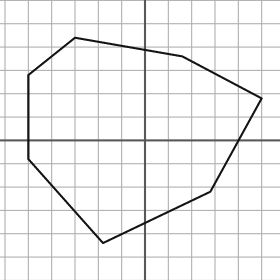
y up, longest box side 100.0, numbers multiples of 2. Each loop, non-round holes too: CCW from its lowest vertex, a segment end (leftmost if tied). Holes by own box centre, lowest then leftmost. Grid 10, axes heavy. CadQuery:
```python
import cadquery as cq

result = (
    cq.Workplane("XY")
    .moveTo(-18.0, -44.0)
    .lineTo(28.0, -22.0)
    .lineTo(50.0, 18.0)
    .lineTo(16.0, 36.0)
    .lineTo(-30.0, 44.0)
    .lineTo(-50.0, 28.0)
    .lineTo(-50.0, -8.0)
    .close()
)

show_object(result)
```